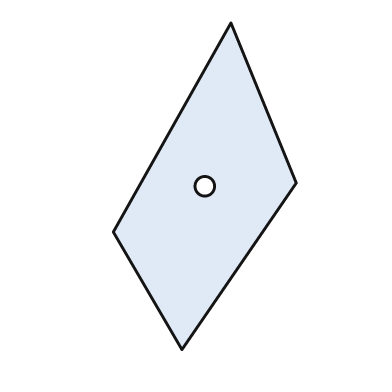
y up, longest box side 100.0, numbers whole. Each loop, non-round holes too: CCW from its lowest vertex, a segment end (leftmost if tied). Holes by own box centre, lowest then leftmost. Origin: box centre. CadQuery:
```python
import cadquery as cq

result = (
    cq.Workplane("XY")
    .moveTo(-7.0, -50.0)
    .lineTo(28.0, 1.0)
    .lineTo(8.0, 50.0)
    .lineTo(-28.0, -14.0)
    .close()
    .moveTo(0.0, 0.0)
    .circle(3.0)
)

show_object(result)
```